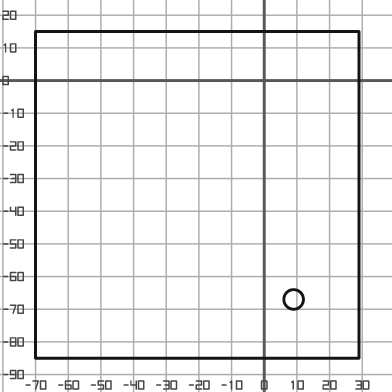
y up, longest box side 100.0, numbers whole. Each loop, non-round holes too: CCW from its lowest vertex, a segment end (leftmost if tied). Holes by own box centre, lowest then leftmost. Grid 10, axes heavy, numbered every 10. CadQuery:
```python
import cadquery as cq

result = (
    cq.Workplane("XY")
    .moveTo(-70.0, -85.0)
    .lineTo(29.0, -85.0)
    .lineTo(29.0, 15.0)
    .lineTo(-70.0, 15.0)
    .close()
    .moveTo(9.0, -67.0)
    .circle(3.0)
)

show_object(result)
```